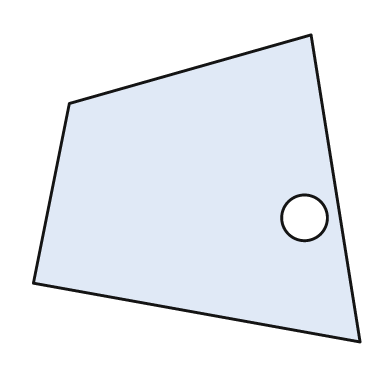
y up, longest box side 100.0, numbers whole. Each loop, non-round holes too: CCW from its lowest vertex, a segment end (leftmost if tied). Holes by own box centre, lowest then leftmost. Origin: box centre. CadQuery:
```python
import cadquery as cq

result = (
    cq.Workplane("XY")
    .moveTo(50.0, -47.0)
    .lineTo(35.0, 47.0)
    .lineTo(-39.0, 26.0)
    .lineTo(-50.0, -29.0)
    .close()
    .moveTo(33.0, -9.0)
    .circle(7.0)
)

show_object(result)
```